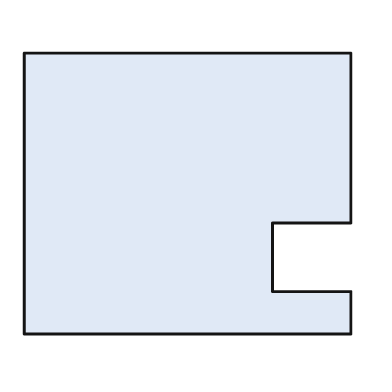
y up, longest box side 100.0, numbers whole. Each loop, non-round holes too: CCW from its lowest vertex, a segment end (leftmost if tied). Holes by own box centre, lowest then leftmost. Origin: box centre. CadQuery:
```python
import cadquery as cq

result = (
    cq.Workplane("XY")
    .moveTo(-50.0, -43.0)
    .lineTo(50.0, -43.0)
    .lineTo(50.0, -30.0)
    .lineTo(26.0, -30.0)
    .lineTo(26.0, -9.0)
    .lineTo(50.0, -9.0)
    .lineTo(50.0, 43.0)
    .lineTo(-50.0, 43.0)
    .close()
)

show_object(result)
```